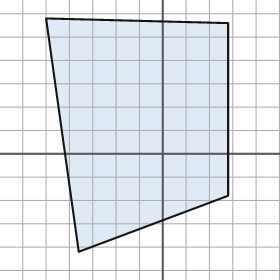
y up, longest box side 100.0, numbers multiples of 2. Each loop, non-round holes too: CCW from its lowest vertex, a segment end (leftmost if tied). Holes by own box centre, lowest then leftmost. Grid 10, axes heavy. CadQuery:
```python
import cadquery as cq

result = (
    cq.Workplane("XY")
    .moveTo(-36.0, -42.0)
    .lineTo(28.0, -18.0)
    .lineTo(28.0, 56.0)
    .lineTo(-50.0, 58.0)
    .close()
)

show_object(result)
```